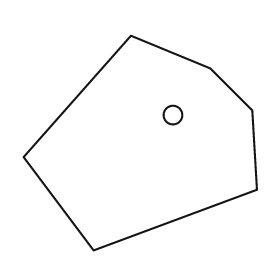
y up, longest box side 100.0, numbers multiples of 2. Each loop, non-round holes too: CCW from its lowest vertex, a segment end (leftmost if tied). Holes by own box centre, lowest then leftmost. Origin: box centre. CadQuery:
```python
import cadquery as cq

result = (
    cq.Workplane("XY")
    .moveTo(-20.0, -46.0)
    .lineTo(50.0, -20.0)
    .lineTo(48.0, 14.0)
    .lineTo(30.0, 32.0)
    .lineTo(-4.0, 46.0)
    .lineTo(-50.0, -6.0)
    .close()
    .moveTo(14.0, 12.0)
    .circle(4.0)
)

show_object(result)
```